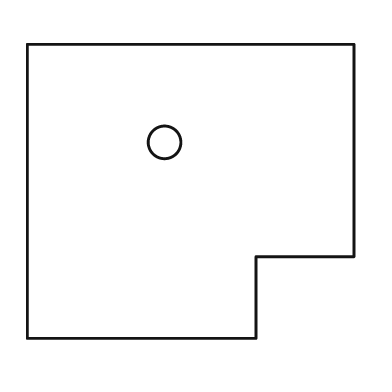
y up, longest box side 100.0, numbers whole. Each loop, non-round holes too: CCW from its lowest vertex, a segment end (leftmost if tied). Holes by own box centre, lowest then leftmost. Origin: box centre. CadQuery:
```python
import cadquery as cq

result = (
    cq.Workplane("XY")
    .moveTo(-50.0, -45.0)
    .lineTo(20.0, -45.0)
    .lineTo(20.0, -20.0)
    .lineTo(50.0, -20.0)
    .lineTo(50.0, 45.0)
    .lineTo(-50.0, 45.0)
    .close()
    .moveTo(-8.0, 15.0)
    .circle(5.0)
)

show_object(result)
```